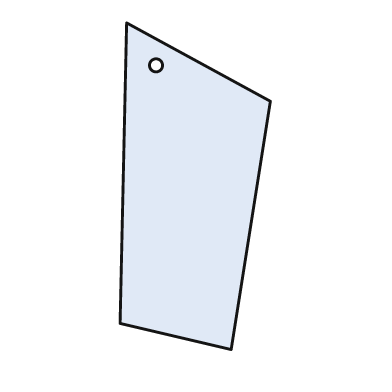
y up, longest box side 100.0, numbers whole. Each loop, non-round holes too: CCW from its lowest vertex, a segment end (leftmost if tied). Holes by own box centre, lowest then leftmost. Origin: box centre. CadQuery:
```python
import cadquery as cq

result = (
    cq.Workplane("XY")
    .moveTo(11.0, -50.0)
    .lineTo(23.0, 26.0)
    .lineTo(-21.0, 50.0)
    .lineTo(-23.0, -42.0)
    .close()
    .moveTo(-12.0, 37.0)
    .circle(2.0)
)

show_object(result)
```